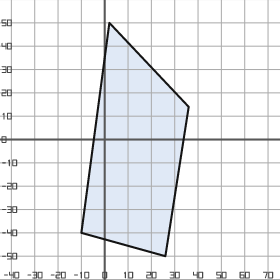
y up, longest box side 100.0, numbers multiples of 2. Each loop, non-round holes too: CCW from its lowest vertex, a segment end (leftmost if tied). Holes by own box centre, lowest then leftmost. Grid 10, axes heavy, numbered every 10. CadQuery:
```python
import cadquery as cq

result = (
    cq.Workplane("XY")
    .moveTo(26.0, -50.0)
    .lineTo(36.0, 14.0)
    .lineTo(2.0, 50.0)
    .lineTo(-10.0, -40.0)
    .close()
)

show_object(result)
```